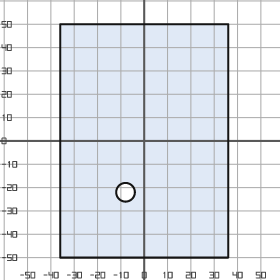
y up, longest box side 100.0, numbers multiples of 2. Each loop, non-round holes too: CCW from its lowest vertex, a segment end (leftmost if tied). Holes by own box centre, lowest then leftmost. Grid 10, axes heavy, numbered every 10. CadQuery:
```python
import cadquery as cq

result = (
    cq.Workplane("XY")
    .moveTo(-36.0, -50.0)
    .lineTo(36.0, -50.0)
    .lineTo(36.0, 50.0)
    .lineTo(-36.0, 50.0)
    .close()
    .moveTo(-8.0, -22.0)
    .circle(4.0)
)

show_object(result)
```